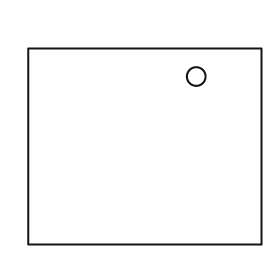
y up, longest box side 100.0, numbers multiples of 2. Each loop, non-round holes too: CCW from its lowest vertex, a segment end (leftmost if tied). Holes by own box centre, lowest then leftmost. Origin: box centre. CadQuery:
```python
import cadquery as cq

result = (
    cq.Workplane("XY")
    .moveTo(-50.0, -42.0)
    .lineTo(50.0, -42.0)
    .lineTo(50.0, 42.0)
    .lineTo(-50.0, 42.0)
    .close()
    .moveTo(22.0, 30.0)
    .circle(4.0)
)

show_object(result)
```